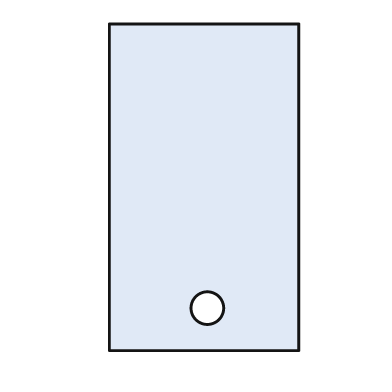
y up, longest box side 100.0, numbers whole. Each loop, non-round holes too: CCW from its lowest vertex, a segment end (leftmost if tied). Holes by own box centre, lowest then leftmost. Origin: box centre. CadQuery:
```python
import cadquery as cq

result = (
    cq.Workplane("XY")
    .moveTo(-29.0, -50.0)
    .lineTo(29.0, -50.0)
    .lineTo(29.0, 50.0)
    .lineTo(-29.0, 50.0)
    .close()
    .moveTo(1.0, -37.0)
    .circle(5.0)
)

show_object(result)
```